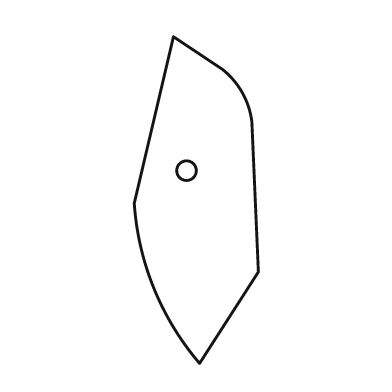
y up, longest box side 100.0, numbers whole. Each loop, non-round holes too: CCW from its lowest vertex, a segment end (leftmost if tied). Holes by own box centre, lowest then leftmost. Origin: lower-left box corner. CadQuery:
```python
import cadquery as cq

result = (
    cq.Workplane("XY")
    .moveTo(20.0, 0.0)
    .lineTo(38.0, 28.0)
    .lineTo(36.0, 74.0)
    .threePointArc((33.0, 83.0), (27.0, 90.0))
    .lineTo(12.0, 100.0)
    .lineTo(0.0, 49.0)
    .threePointArc((6.0, 23.0), (20.0, 0.0))
    .close()
    .moveTo(16.0, 59.0)
    .circle(3.0)
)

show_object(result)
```